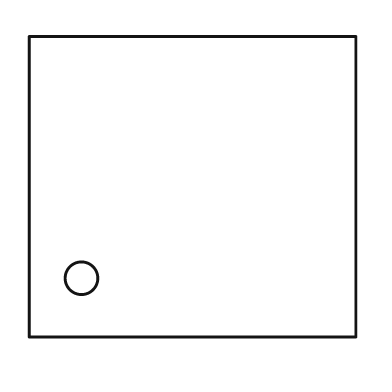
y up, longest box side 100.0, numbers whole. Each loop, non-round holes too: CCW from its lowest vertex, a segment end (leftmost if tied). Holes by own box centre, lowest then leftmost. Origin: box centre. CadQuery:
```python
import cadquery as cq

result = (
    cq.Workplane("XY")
    .moveTo(-50.0, -46.0)
    .lineTo(50.0, -46.0)
    .lineTo(50.0, 46.0)
    .lineTo(-50.0, 46.0)
    .close()
    .moveTo(-34.0, -28.0)
    .circle(5.0)
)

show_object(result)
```